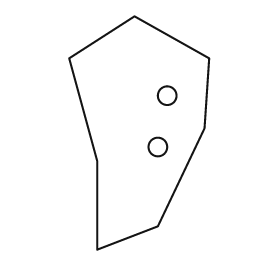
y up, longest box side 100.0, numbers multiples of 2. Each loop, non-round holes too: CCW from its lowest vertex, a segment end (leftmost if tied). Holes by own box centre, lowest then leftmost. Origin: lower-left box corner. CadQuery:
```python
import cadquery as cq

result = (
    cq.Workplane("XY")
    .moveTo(12.0, 0.0)
    .lineTo(38.0, 10.0)
    .lineTo(58.0, 52.0)
    .lineTo(60.0, 82.0)
    .lineTo(28.0, 100.0)
    .lineTo(0.0, 82.0)
    .lineTo(12.0, 38.0)
    .close()
    .moveTo(38.0, 44.0)
    .circle(4.0)
    .moveTo(42.0, 66.0)
    .circle(4.0)
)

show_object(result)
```